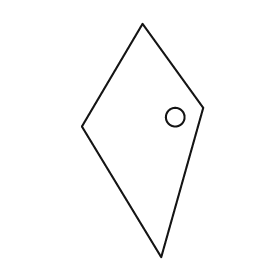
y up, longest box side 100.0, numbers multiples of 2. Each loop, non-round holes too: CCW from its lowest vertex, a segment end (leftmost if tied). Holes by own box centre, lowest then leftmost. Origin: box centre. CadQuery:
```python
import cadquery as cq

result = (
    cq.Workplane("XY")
    .moveTo(8.0, -50.0)
    .lineTo(26.0, 14.0)
    .lineTo(0.0, 50.0)
    .lineTo(-26.0, 6.0)
    .close()
    .moveTo(14.0, 10.0)
    .circle(4.0)
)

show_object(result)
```